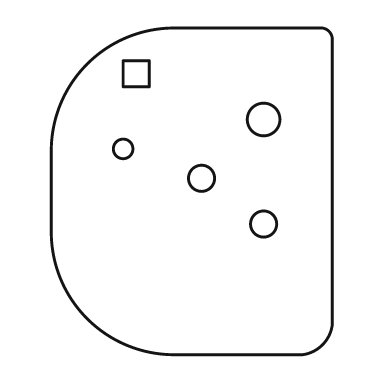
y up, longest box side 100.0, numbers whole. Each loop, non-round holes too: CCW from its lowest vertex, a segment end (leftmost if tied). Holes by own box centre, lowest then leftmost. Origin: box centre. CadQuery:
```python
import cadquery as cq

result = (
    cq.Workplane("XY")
    .moveTo(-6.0, -50.0)
    .lineTo(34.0, -50.0)
    .threePointArc((40.0, -47.0), (43.0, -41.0))
    .lineTo(43.0, 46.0)
    .threePointArc((42.0, 49.0), (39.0, 50.0))
    .lineTo(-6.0, 50.0)
    .threePointArc((-32.0, 39.0), (-43.0, 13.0))
    .lineTo(-43.0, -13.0)
    .threePointArc((-32.0, -39.0), (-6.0, -50.0))
    .close()
    .moveTo(22.0, -10.0)
    .circle(4.0)
    .moveTo(3.0, 4.0)
    .circle(4.0)
    .moveTo(-21.0, 13.0)
    .circle(3.0)
    .moveTo(22.0, 22.0)
    .circle(5.0)
    .moveTo(-21.0, 32.0)
    .lineTo(-13.0, 32.0)
    .lineTo(-13.0, 40.0)
    .lineTo(-21.0, 40.0)
    .close()
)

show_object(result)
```